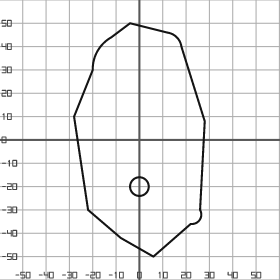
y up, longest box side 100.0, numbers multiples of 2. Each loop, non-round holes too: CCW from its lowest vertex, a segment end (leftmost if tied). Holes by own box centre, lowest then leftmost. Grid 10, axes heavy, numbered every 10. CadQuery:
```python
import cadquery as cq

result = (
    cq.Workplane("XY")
    .moveTo(6.0, -50.0)
    .lineTo(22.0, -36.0)
    .threePointArc((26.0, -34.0), (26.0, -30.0))
    .lineTo(28.0, 8.0)
    .lineTo(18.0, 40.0)
    .threePointArc((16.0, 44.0), (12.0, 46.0))
    .lineTo(-4.0, 50.0)
    .lineTo(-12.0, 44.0)
    .threePointArc((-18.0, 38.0), (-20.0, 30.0))
    .lineTo(-28.0, 10.0)
    .lineTo(-22.0, -30.0)
    .lineTo(-8.0, -42.0)
    .close()
    .moveTo(0.0, -20.0)
    .circle(4.0)
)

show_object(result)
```